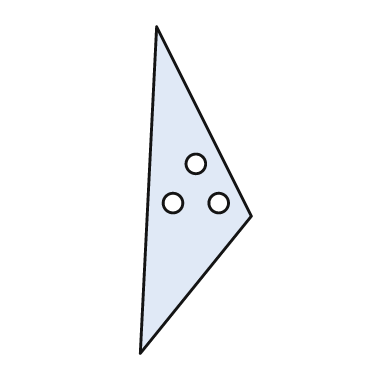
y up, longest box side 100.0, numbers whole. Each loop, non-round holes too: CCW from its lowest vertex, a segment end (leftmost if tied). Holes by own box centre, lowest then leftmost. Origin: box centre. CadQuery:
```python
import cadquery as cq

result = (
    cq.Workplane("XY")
    .moveTo(-17.0, -50.0)
    .lineTo(17.0, -8.0)
    .lineTo(-12.0, 50.0)
    .close()
    .moveTo(-7.0, -4.0)
    .circle(3.0)
    .moveTo(7.0, -4.0)
    .circle(3.0)
    .moveTo(0.0, 8.0)
    .circle(3.0)
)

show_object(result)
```